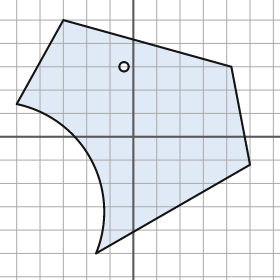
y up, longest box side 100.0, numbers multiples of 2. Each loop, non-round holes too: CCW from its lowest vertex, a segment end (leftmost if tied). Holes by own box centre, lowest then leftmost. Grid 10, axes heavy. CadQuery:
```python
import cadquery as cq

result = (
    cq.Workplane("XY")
    .moveTo(-16.0, -50.0)
    .lineTo(50.0, -12.0)
    .lineTo(42.0, 30.0)
    .lineTo(-30.0, 50.0)
    .lineTo(-50.0, 14.0)
    .threePointArc((-18.0, -10.0), (-16.0, -50.0))
    .close()
    .moveTo(-4.0, 30.0)
    .circle(2.0)
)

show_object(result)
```